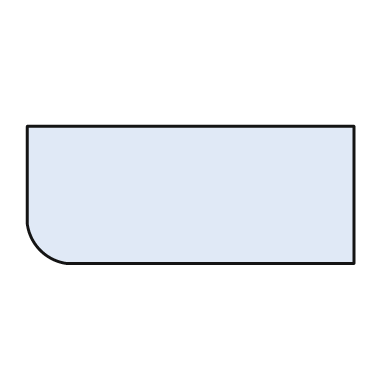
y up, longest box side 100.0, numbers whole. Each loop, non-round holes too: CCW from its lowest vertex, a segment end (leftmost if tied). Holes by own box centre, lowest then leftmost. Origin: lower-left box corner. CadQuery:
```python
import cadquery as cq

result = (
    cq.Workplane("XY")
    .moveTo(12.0, 0.0)
    .lineTo(100.0, 0.0)
    .lineTo(100.0, 42.0)
    .lineTo(0.0, 42.0)
    .lineTo(0.0, 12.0)
    .threePointArc((4.0, 4.0), (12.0, 0.0))
    .close()
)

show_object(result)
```